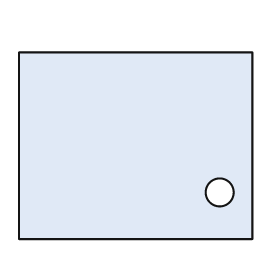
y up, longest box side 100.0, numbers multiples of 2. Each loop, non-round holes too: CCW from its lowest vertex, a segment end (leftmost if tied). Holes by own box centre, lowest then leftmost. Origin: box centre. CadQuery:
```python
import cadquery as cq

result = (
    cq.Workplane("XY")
    .moveTo(-50.0, -40.0)
    .lineTo(50.0, -40.0)
    .lineTo(50.0, 40.0)
    .lineTo(-50.0, 40.0)
    .close()
    .moveTo(36.0, -20.0)
    .circle(6.0)
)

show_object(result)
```